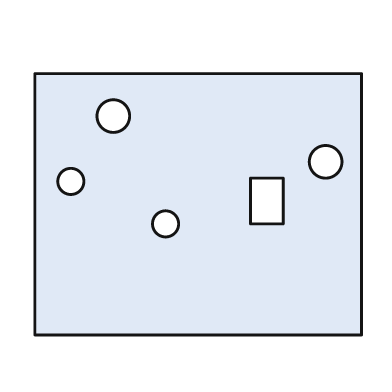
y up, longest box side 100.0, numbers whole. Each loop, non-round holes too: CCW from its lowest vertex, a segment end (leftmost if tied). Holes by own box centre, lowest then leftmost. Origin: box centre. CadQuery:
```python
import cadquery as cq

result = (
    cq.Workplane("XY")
    .moveTo(-50.0, -40.0)
    .lineTo(50.0, -40.0)
    .lineTo(50.0, 40.0)
    .lineTo(-50.0, 40.0)
    .close()
    .moveTo(-10.0, -6.0)
    .circle(4.0)
    .moveTo(16.0, -6.0)
    .lineTo(26.0, -6.0)
    .lineTo(26.0, 8.0)
    .lineTo(16.0, 8.0)
    .close()
    .moveTo(-39.0, 7.0)
    .circle(4.0)
    .moveTo(39.0, 13.0)
    .circle(5.0)
    .moveTo(-26.0, 27.0)
    .circle(5.0)
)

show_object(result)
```